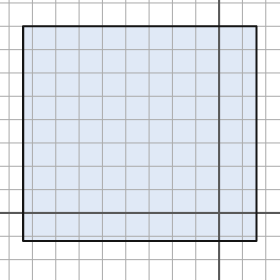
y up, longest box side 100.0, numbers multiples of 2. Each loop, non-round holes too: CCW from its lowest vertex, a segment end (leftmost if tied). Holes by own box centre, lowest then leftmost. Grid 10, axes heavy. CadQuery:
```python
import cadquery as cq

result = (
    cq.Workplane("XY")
    .moveTo(-84.0, -12.0)
    .lineTo(16.0, -12.0)
    .lineTo(16.0, 80.0)
    .lineTo(-84.0, 80.0)
    .close()
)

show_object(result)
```